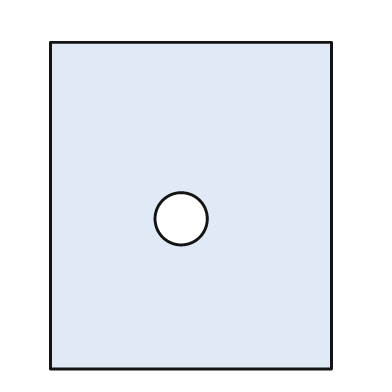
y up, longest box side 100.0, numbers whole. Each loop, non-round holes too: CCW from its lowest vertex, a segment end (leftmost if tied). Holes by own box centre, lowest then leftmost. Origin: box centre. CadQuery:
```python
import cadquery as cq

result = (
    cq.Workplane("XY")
    .moveTo(-43.0, -50.0)
    .lineTo(43.0, -50.0)
    .lineTo(43.0, 50.0)
    .lineTo(-43.0, 50.0)
    .close()
    .moveTo(-3.0, -4.0)
    .circle(8.0)
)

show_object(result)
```